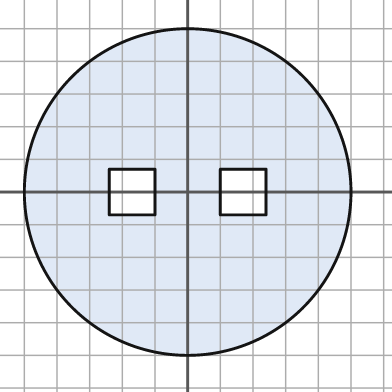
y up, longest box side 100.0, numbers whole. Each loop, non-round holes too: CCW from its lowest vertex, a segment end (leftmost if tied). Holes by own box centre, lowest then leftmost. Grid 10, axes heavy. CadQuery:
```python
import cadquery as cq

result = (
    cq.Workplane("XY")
    .moveTo(0.0, 0.0)
    .circle(50.0)
    .moveTo(-24.0, -7.0)
    .lineTo(-10.0, -7.0)
    .lineTo(-10.0, 7.0)
    .lineTo(-24.0, 7.0)
    .close()
    .moveTo(10.0, -7.0)
    .lineTo(24.0, -7.0)
    .lineTo(24.0, 7.0)
    .lineTo(10.0, 7.0)
    .close()
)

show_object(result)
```